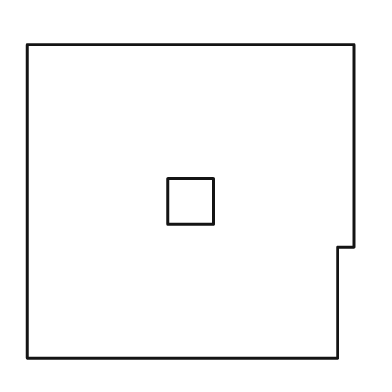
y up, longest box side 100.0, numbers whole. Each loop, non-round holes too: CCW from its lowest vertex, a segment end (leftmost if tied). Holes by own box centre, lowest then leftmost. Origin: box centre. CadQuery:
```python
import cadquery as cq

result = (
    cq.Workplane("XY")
    .moveTo(-50.0, -48.0)
    .lineTo(45.0, -48.0)
    .lineTo(45.0, -14.0)
    .lineTo(50.0, -14.0)
    .lineTo(50.0, 48.0)
    .lineTo(-50.0, 48.0)
    .close()
    .moveTo(-7.0, -7.0)
    .lineTo(7.0, -7.0)
    .lineTo(7.0, 7.0)
    .lineTo(-7.0, 7.0)
    .close()
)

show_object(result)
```